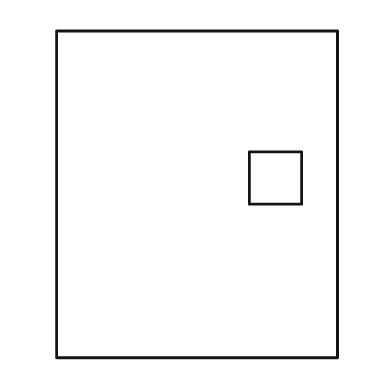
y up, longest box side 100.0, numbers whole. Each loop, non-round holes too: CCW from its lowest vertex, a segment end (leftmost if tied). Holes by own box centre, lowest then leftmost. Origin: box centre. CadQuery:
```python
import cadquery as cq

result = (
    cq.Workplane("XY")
    .moveTo(-43.0, -50.0)
    .lineTo(43.0, -50.0)
    .lineTo(43.0, 50.0)
    .lineTo(-43.0, 50.0)
    .close()
    .moveTo(16.0, -3.0)
    .lineTo(32.0, -3.0)
    .lineTo(32.0, 13.0)
    .lineTo(16.0, 13.0)
    .close()
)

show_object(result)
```